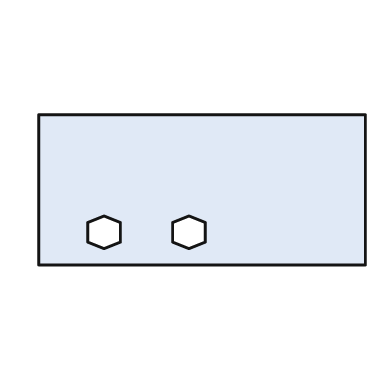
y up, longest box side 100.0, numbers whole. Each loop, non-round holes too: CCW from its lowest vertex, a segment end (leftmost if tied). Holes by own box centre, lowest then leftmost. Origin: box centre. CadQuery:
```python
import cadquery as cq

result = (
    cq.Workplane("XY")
    .moveTo(-50.0, -23.0)
    .lineTo(50.0, -23.0)
    .lineTo(50.0, 23.0)
    .lineTo(-50.0, 23.0)
    .close()
    .moveTo(-30.0, -18.0)
    .lineTo(-25.0, -16.0)
    .lineTo(-25.0, -10.0)
    .lineTo(-30.0, -8.0)
    .lineTo(-35.0, -10.0)
    .lineTo(-35.0, -16.0)
    .close()
    .moveTo(-4.0, -18.0)
    .lineTo(1.0, -16.0)
    .lineTo(1.0, -10.0)
    .lineTo(-4.0, -8.0)
    .lineTo(-9.0, -10.0)
    .lineTo(-9.0, -16.0)
    .close()
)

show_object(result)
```